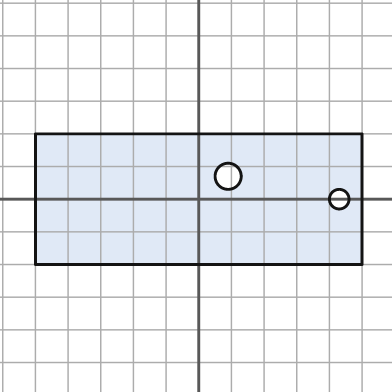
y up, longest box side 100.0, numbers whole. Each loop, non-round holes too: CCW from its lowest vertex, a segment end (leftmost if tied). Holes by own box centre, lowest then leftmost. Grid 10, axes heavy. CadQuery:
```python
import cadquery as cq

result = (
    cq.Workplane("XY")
    .moveTo(-50.0, -20.0)
    .lineTo(50.0, -20.0)
    .lineTo(50.0, 20.0)
    .lineTo(-50.0, 20.0)
    .close()
    .moveTo(43.0, 0.0)
    .circle(3.0)
    .moveTo(9.0, 7.0)
    .circle(4.0)
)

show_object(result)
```